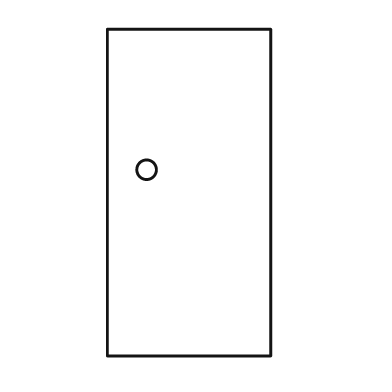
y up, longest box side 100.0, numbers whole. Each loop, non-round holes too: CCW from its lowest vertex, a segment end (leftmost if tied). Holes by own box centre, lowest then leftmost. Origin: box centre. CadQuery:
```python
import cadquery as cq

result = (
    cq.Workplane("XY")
    .moveTo(-25.0, -50.0)
    .lineTo(25.0, -50.0)
    .lineTo(25.0, 50.0)
    .lineTo(-25.0, 50.0)
    .close()
    .moveTo(-13.0, 7.0)
    .circle(3.0)
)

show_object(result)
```